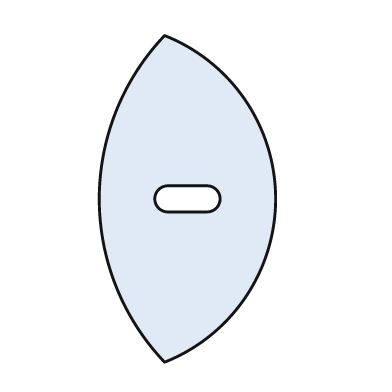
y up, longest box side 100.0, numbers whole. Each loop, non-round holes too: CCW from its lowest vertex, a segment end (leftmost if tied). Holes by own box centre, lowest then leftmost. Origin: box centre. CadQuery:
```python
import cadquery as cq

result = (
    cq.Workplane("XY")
    .moveTo(-7.0, -50.0)
    .threePointArc((27.0, 0.0), (-7.0, 50.0))
    .threePointArc((-27.0, 0.0), (-7.0, -50.0))
    .close()
    .moveTo(-6.0, -4.0)
    .lineTo(6.0, -4.0)
    .threePointArc((10.0, 0.0), (6.0, 4.0))
    .lineTo(-6.0, 4.0)
    .threePointArc((-10.0, 0.0), (-6.0, -4.0))
    .close()
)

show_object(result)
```